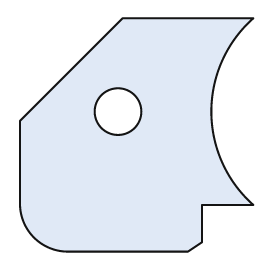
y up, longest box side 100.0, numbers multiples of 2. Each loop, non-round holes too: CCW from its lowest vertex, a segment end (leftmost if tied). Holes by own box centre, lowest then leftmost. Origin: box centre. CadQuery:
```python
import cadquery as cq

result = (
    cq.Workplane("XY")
    .moveTo(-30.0, -50.0)
    .lineTo(22.0, -50.0)
    .lineTo(28.0, -46.0)
    .lineTo(28.0, -30.0)
    .lineTo(50.0, -30.0)
    .threePointArc((32.0, 10.0), (50.0, 50.0))
    .lineTo(-6.0, 50.0)
    .lineTo(-50.0, 6.0)
    .lineTo(-50.0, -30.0)
    .threePointArc((-44.0, -44.0), (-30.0, -50.0))
    .close()
    .moveTo(-8.0, 10.0)
    .circle(10.0)
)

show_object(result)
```